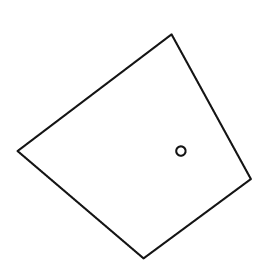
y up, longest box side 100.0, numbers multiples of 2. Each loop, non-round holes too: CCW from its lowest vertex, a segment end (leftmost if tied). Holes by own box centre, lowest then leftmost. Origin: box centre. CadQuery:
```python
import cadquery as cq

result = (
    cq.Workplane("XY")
    .moveTo(4.0, -48.0)
    .lineTo(50.0, -14.0)
    .lineTo(16.0, 48.0)
    .lineTo(-50.0, -2.0)
    .close()
    .moveTo(20.0, -2.0)
    .circle(2.0)
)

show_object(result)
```